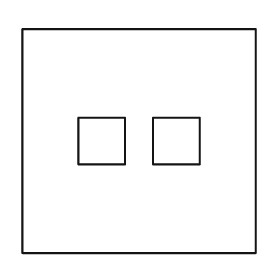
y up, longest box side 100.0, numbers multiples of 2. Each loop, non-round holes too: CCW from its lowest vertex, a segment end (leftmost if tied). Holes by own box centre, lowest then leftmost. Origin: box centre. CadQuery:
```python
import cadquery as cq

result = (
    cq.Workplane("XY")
    .moveTo(-50.0, -48.0)
    .lineTo(50.0, -48.0)
    .lineTo(50.0, 48.0)
    .lineTo(-50.0, 48.0)
    .close()
    .moveTo(-26.0, -10.0)
    .lineTo(-6.0, -10.0)
    .lineTo(-6.0, 10.0)
    .lineTo(-26.0, 10.0)
    .close()
    .moveTo(6.0, -10.0)
    .lineTo(26.0, -10.0)
    .lineTo(26.0, 10.0)
    .lineTo(6.0, 10.0)
    .close()
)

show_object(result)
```